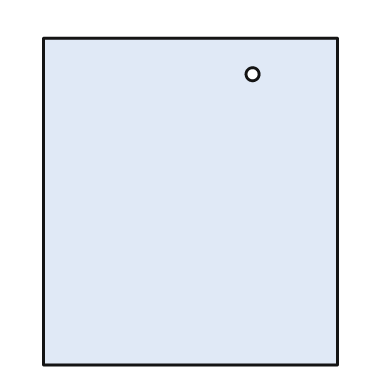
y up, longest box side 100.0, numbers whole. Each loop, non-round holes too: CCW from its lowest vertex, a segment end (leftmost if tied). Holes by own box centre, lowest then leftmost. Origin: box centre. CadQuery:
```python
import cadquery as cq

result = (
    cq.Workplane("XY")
    .moveTo(-45.0, -50.0)
    .lineTo(45.0, -50.0)
    .lineTo(45.0, 50.0)
    .lineTo(-45.0, 50.0)
    .close()
    .moveTo(19.0, 39.0)
    .circle(2.0)
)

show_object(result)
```